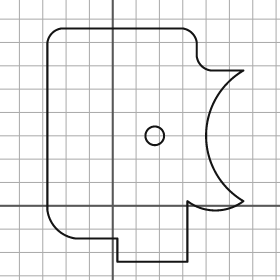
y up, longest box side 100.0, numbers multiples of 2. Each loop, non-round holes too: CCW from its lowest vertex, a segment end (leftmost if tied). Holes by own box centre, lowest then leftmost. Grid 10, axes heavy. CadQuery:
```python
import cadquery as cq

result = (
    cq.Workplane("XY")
    .moveTo(2.0, -24.0)
    .lineTo(32.0, -24.0)
    .lineTo(32.0, 2.0)
    .threePointArc((44.0, -2.0), (56.0, 2.0))
    .threePointArc((40.0, 30.0), (56.0, 58.0))
    .lineTo(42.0, 58.0)
    .threePointArc((38.0, 60.0), (36.0, 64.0))
    .lineTo(36.0, 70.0)
    .threePointArc((34.0, 74.0), (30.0, 76.0))
    .lineTo(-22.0, 76.0)
    .threePointArc((-26.0, 74.0), (-28.0, 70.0))
    .lineTo(-28.0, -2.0)
    .threePointArc((-24.0, -10.0), (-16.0, -14.0))
    .lineTo(2.0, -14.0)
    .close()
    .moveTo(18.0, 30.0)
    .circle(4.0)
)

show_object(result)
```